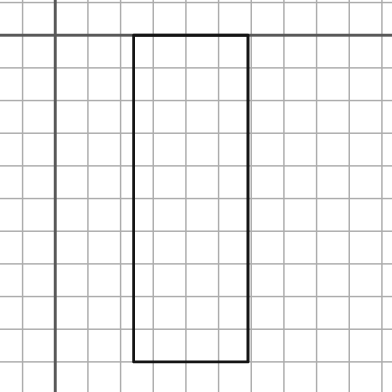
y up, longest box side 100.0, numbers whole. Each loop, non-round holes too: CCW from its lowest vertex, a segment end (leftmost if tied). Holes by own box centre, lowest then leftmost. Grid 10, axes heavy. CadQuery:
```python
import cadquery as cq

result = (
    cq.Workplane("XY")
    .moveTo(24.0, -100.0)
    .lineTo(59.0, -100.0)
    .lineTo(59.0, 0.0)
    .lineTo(24.0, 0.0)
    .close()
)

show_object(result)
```